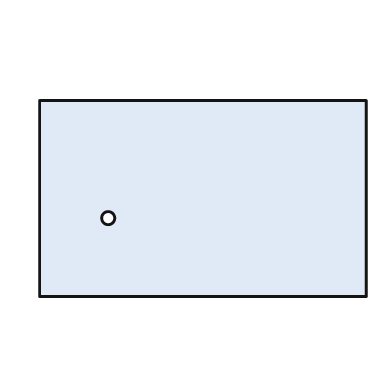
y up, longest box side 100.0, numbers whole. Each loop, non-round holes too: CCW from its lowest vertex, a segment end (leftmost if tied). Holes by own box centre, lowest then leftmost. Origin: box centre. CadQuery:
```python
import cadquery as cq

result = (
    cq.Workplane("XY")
    .moveTo(-50.0, -30.0)
    .lineTo(50.0, -30.0)
    .lineTo(50.0, 30.0)
    .lineTo(-50.0, 30.0)
    .close()
    .moveTo(-29.0, -6.0)
    .circle(2.0)
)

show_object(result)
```